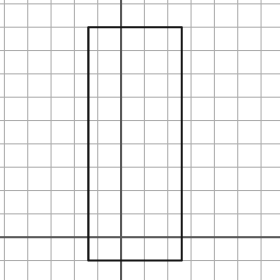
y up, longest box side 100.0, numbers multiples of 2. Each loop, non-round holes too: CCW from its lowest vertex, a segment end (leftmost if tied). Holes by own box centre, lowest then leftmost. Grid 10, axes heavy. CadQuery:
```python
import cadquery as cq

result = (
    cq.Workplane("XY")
    .moveTo(-14.0, -10.0)
    .lineTo(26.0, -10.0)
    .lineTo(26.0, 90.0)
    .lineTo(-14.0, 90.0)
    .close()
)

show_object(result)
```